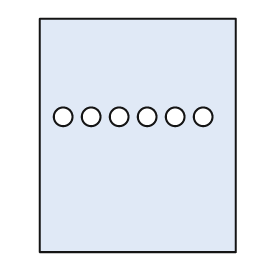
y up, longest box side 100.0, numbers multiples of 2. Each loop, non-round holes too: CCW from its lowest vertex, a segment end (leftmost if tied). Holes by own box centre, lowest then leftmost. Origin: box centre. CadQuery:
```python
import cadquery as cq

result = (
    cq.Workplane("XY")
    .moveTo(-42.0, -50.0)
    .lineTo(42.0, -50.0)
    .lineTo(42.0, 50.0)
    .lineTo(-42.0, 50.0)
    .close()
    .moveTo(-32.0, 8.0)
    .circle(4.0)
    .moveTo(-20.0, 8.0)
    .circle(4.0)
    .moveTo(-8.0, 8.0)
    .circle(4.0)
    .moveTo(4.0, 8.0)
    .circle(4.0)
    .moveTo(16.0, 8.0)
    .circle(4.0)
    .moveTo(28.0, 8.0)
    .circle(4.0)
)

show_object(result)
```